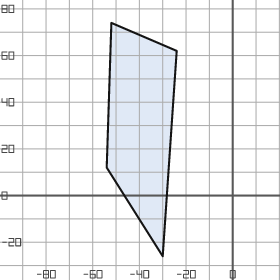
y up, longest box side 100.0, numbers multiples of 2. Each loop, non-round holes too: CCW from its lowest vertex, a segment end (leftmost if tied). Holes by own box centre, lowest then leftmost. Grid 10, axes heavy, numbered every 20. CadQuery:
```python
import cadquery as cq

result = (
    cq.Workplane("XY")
    .moveTo(-30.0, -26.0)
    .lineTo(-24.0, 62.0)
    .lineTo(-52.0, 74.0)
    .lineTo(-54.0, 12.0)
    .close()
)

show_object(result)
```